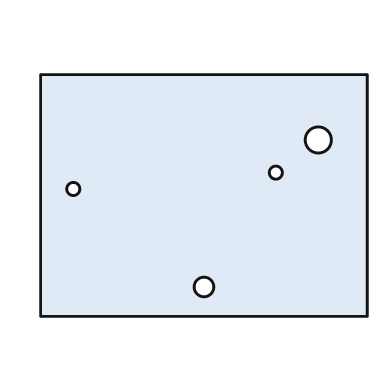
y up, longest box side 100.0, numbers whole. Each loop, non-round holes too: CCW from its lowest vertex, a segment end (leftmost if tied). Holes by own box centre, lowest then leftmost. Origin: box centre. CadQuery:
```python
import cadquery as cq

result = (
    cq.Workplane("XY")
    .moveTo(-50.0, -37.0)
    .lineTo(50.0, -37.0)
    .lineTo(50.0, 37.0)
    .lineTo(-50.0, 37.0)
    .close()
    .moveTo(0.0, -28.0)
    .circle(3.0)
    .moveTo(-40.0, 2.0)
    .circle(2.0)
    .moveTo(22.0, 7.0)
    .circle(2.0)
    .moveTo(35.0, 17.0)
    .circle(4.0)
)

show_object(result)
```